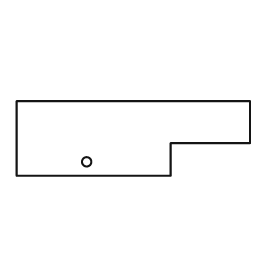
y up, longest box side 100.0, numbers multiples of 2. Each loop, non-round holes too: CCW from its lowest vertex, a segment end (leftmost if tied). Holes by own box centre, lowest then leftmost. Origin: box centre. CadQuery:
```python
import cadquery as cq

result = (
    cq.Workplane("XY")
    .moveTo(-50.0, -16.0)
    .lineTo(16.0, -16.0)
    .lineTo(16.0, -2.0)
    .lineTo(50.0, -2.0)
    .lineTo(50.0, 16.0)
    .lineTo(-50.0, 16.0)
    .close()
    .moveTo(-20.0, -10.0)
    .circle(2.0)
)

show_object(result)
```